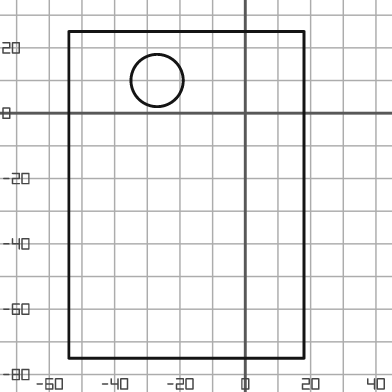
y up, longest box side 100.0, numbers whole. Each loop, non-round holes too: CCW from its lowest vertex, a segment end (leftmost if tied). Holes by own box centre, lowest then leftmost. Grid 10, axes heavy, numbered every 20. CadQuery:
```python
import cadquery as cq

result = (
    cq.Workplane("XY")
    .moveTo(-54.0, -75.0)
    .lineTo(18.0, -75.0)
    .lineTo(18.0, 25.0)
    .lineTo(-54.0, 25.0)
    .close()
    .moveTo(-27.0, 10.0)
    .circle(8.0)
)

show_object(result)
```